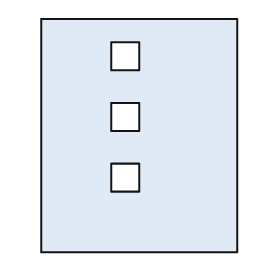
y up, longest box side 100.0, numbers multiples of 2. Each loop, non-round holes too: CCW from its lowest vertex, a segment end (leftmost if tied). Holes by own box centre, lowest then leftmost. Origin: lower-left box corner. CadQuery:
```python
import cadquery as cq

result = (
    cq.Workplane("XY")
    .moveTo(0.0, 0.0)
    .lineTo(84.0, 0.0)
    .lineTo(84.0, 100.0)
    .lineTo(0.0, 100.0)
    .close()
    .moveTo(30.0, 26.0)
    .lineTo(42.0, 26.0)
    .lineTo(42.0, 38.0)
    .lineTo(30.0, 38.0)
    .close()
    .moveTo(30.0, 52.0)
    .lineTo(42.0, 52.0)
    .lineTo(42.0, 64.0)
    .lineTo(30.0, 64.0)
    .close()
    .moveTo(30.0, 78.0)
    .lineTo(42.0, 78.0)
    .lineTo(42.0, 90.0)
    .lineTo(30.0, 90.0)
    .close()
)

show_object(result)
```